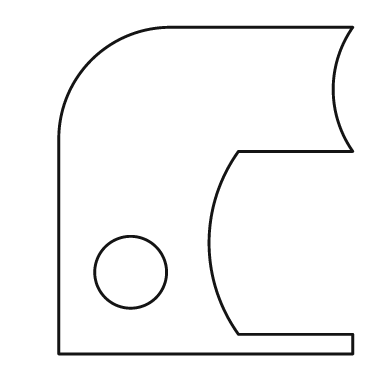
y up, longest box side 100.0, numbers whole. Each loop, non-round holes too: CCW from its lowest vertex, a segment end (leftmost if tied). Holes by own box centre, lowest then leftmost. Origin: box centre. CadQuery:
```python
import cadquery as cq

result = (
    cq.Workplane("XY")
    .moveTo(-45.0, -50.0)
    .lineTo(45.0, -50.0)
    .lineTo(45.0, -44.0)
    .lineTo(10.0, -44.0)
    .threePointArc((1.0, -16.0), (10.0, 12.0))
    .lineTo(45.0, 12.0)
    .threePointArc((39.0, 31.0), (45.0, 50.0))
    .lineTo(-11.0, 50.0)
    .threePointArc((-35.0, 40.0), (-45.0, 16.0))
    .close()
    .moveTo(-23.0, -25.0)
    .circle(11.0)
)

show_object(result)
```